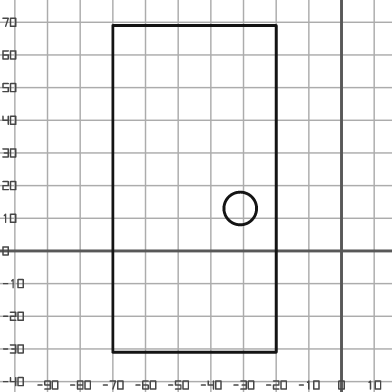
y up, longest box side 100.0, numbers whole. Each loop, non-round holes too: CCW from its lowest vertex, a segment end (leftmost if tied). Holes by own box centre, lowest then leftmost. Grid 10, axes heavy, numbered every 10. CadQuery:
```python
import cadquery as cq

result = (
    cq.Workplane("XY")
    .moveTo(-70.0, -31.0)
    .lineTo(-20.0, -31.0)
    .lineTo(-20.0, 69.0)
    .lineTo(-70.0, 69.0)
    .close()
    .moveTo(-31.0, 13.0)
    .circle(5.0)
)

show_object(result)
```